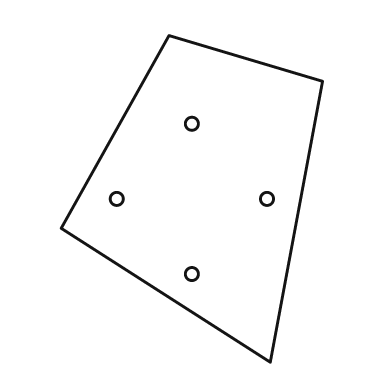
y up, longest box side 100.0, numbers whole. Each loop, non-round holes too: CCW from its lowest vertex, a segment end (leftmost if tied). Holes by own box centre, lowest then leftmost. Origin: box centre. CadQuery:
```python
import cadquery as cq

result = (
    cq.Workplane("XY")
    .moveTo(24.0, -50.0)
    .lineTo(40.0, 36.0)
    .lineTo(-7.0, 50.0)
    .lineTo(-40.0, -9.0)
    .close()
    .moveTo(0.0, -23.0)
    .circle(2.0)
    .moveTo(-23.0, 0.0)
    .circle(2.0)
    .moveTo(23.0, 0.0)
    .circle(2.0)
    .moveTo(0.0, 23.0)
    .circle(2.0)
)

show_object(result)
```